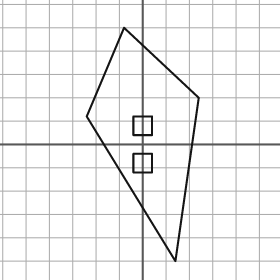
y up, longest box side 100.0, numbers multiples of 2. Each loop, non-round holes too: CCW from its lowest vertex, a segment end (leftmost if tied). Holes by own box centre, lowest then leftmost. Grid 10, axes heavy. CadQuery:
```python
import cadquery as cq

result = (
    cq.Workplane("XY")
    .moveTo(14.0, -50.0)
    .lineTo(24.0, 20.0)
    .lineTo(-8.0, 50.0)
    .lineTo(-24.0, 12.0)
    .close()
    .moveTo(-4.0, -12.0)
    .lineTo(4.0, -12.0)
    .lineTo(4.0, -4.0)
    .lineTo(-4.0, -4.0)
    .close()
    .moveTo(-4.0, 4.0)
    .lineTo(4.0, 4.0)
    .lineTo(4.0, 12.0)
    .lineTo(-4.0, 12.0)
    .close()
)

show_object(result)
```